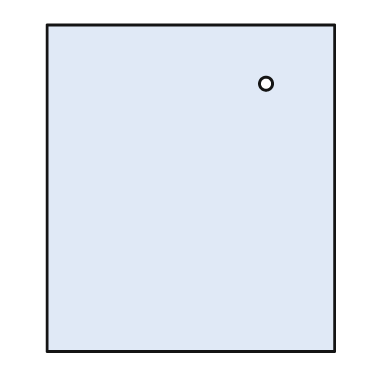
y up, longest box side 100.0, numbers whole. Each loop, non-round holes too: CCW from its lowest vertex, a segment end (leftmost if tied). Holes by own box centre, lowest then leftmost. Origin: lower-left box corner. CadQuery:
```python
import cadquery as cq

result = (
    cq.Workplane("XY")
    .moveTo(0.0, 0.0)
    .lineTo(88.0, 0.0)
    .lineTo(88.0, 100.0)
    .lineTo(0.0, 100.0)
    .close()
    .moveTo(67.0, 82.0)
    .circle(2.0)
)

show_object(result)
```